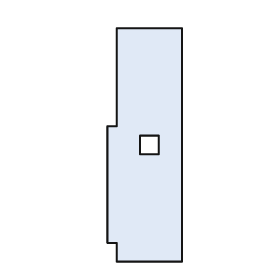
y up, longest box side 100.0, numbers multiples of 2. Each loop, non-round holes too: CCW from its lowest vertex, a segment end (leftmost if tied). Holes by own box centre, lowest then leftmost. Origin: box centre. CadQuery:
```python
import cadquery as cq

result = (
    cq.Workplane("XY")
    .moveTo(-12.0, -50.0)
    .lineTo(16.0, -50.0)
    .lineTo(16.0, 50.0)
    .lineTo(-12.0, 50.0)
    .lineTo(-12.0, 8.0)
    .lineTo(-16.0, 8.0)
    .lineTo(-16.0, -42.0)
    .lineTo(-12.0, -42.0)
    .close()
    .moveTo(-2.0, -4.0)
    .lineTo(6.0, -4.0)
    .lineTo(6.0, 4.0)
    .lineTo(-2.0, 4.0)
    .close()
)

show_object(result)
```